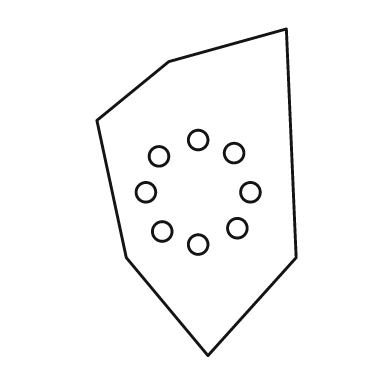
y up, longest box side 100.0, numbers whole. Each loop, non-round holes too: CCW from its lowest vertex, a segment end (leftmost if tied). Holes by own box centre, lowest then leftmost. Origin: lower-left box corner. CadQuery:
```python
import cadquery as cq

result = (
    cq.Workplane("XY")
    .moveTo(34.0, 0.0)
    .lineTo(61.0, 30.0)
    .lineTo(58.0, 100.0)
    .lineTo(22.0, 90.0)
    .lineTo(0.0, 72.0)
    .lineTo(9.0, 30.0)
    .close()
    .moveTo(31.0, 34.0)
    .circle(3.0)
    .moveTo(20.0, 38.0)
    .circle(3.0)
    .moveTo(43.0, 39.0)
    .circle(3.0)
    .moveTo(15.0, 50.0)
    .circle(3.0)
    .moveTo(47.0, 50.0)
    .circle(3.0)
    .moveTo(19.0, 61.0)
    .circle(3.0)
    .moveTo(42.0, 62.0)
    .circle(3.0)
    .moveTo(31.0, 66.0)
    .circle(3.0)
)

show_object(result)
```